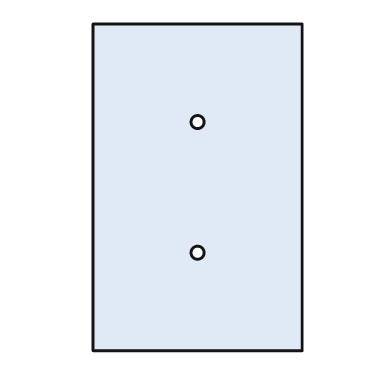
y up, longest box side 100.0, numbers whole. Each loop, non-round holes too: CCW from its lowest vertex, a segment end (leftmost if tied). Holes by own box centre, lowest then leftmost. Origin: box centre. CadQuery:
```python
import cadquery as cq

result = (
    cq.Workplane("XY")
    .moveTo(-32.0, -50.0)
    .lineTo(32.0, -50.0)
    .lineTo(32.0, 50.0)
    .lineTo(-32.0, 50.0)
    .close()
    .moveTo(0.0, -20.0)
    .circle(2.0)
    .moveTo(0.0, 20.0)
    .circle(2.0)
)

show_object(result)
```